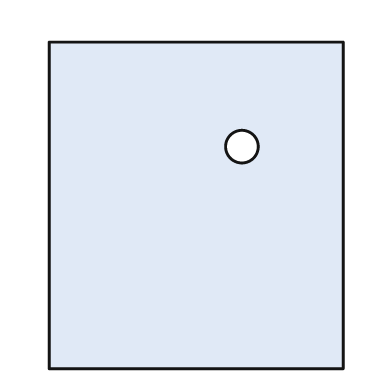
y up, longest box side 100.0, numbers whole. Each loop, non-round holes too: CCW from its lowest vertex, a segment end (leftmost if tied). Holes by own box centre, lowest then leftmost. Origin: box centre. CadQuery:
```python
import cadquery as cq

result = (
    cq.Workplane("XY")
    .moveTo(-45.0, -50.0)
    .lineTo(45.0, -50.0)
    .lineTo(45.0, 50.0)
    .lineTo(-45.0, 50.0)
    .close()
    .moveTo(14.0, 18.0)
    .circle(5.0)
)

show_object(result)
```